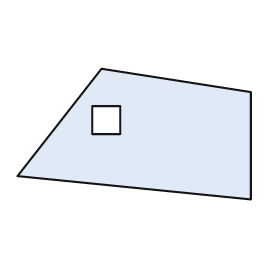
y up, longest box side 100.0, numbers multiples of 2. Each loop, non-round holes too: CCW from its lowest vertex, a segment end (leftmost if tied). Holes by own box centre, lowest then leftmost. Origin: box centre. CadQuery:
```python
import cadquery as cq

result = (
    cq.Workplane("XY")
    .moveTo(50.0, -28.0)
    .lineTo(50.0, 18.0)
    .lineTo(-14.0, 28.0)
    .lineTo(-50.0, -18.0)
    .close()
    .moveTo(-18.0, 0.0)
    .lineTo(-6.0, 0.0)
    .lineTo(-6.0, 12.0)
    .lineTo(-18.0, 12.0)
    .close()
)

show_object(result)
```